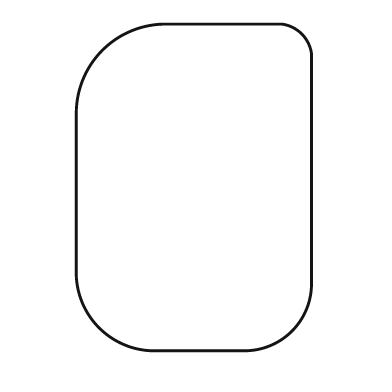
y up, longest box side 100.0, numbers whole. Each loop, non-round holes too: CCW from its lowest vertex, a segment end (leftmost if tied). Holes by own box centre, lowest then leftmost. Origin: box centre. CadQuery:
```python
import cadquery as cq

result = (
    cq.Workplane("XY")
    .moveTo(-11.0, -50.0)
    .lineTo(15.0, -50.0)
    .threePointArc((30.0, -44.0), (36.0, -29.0))
    .lineTo(36.0, 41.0)
    .threePointArc((33.0, 47.0), (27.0, 50.0))
    .lineTo(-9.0, 50.0)
    .threePointArc((-28.0, 42.0), (-36.0, 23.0))
    .lineTo(-36.0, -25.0)
    .threePointArc((-29.0, -43.0), (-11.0, -50.0))
    .close()
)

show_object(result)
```